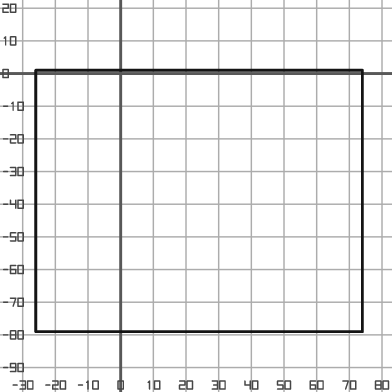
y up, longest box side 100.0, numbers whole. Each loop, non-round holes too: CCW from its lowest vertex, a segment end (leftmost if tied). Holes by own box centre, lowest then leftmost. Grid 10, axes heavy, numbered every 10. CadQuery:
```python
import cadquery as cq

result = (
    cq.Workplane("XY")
    .moveTo(-26.0, -79.0)
    .lineTo(74.0, -79.0)
    .lineTo(74.0, 1.0)
    .lineTo(-26.0, 1.0)
    .close()
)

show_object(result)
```